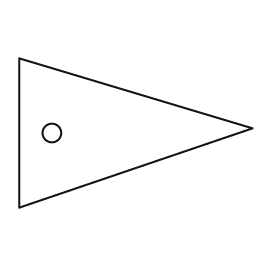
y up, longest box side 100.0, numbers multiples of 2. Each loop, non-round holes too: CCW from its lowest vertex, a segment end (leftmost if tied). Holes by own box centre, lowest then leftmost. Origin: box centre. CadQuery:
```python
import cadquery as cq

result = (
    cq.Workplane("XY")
    .moveTo(-50.0, -32.0)
    .lineTo(50.0, 2.0)
    .lineTo(-50.0, 32.0)
    .close()
    .moveTo(-36.0, 0.0)
    .circle(4.0)
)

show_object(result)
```